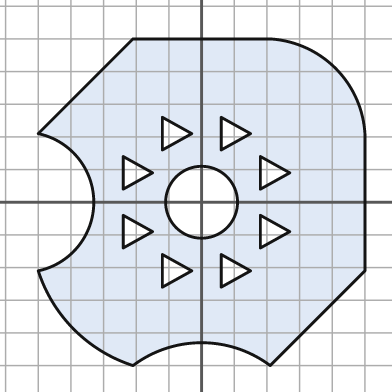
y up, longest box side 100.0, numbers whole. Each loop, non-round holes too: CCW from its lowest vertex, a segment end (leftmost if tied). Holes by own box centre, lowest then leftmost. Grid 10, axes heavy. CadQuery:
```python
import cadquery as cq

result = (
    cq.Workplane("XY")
    .moveTo(-21.0, -50.0)
    .threePointArc((0.0, -43.0), (21.0, -50.0))
    .lineTo(50.0, -21.0)
    .lineTo(50.0, 21.0)
    .threePointArc((41.0, 41.0), (21.0, 50.0))
    .lineTo(-21.0, 50.0)
    .lineTo(-50.0, 21.0)
    .threePointArc((-33.0, 0.0), (-50.0, -21.0))
    .threePointArc((-39.0, -39.0), (-21.0, -50.0))
    .close()
    .moveTo(-12.0, -26.0)
    .lineTo(-3.0, -21.0)
    .lineTo(-12.0, -16.0)
    .close()
    .moveTo(6.0, -26.0)
    .lineTo(15.0, -21.0)
    .lineTo(6.0, -16.0)
    .close()
    .moveTo(-24.0, -14.0)
    .lineTo(-15.0, -9.0)
    .lineTo(-24.0, -4.0)
    .close()
    .moveTo(18.0, -14.0)
    .lineTo(27.0, -9.0)
    .lineTo(18.0, -4.0)
    .close()
    .moveTo(0.0, 0.0)
    .circle(11.0)
    .moveTo(-24.0, 4.0)
    .lineTo(-15.0, 9.0)
    .lineTo(-24.0, 14.0)
    .close()
    .moveTo(18.0, 4.0)
    .lineTo(27.0, 9.0)
    .lineTo(18.0, 14.0)
    .close()
    .moveTo(-12.0, 16.0)
    .lineTo(-3.0, 21.0)
    .lineTo(-12.0, 26.0)
    .close()
    .moveTo(6.0, 16.0)
    .lineTo(15.0, 21.0)
    .lineTo(6.0, 26.0)
    .close()
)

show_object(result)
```